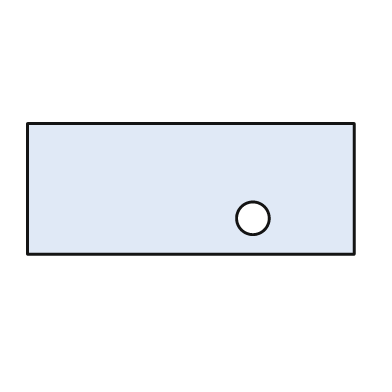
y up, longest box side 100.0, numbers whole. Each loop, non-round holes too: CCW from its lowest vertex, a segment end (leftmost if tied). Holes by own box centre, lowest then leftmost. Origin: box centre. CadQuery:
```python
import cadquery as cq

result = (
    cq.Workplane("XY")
    .moveTo(-50.0, -20.0)
    .lineTo(50.0, -20.0)
    .lineTo(50.0, 20.0)
    .lineTo(-50.0, 20.0)
    .close()
    .moveTo(19.0, -9.0)
    .circle(5.0)
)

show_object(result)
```